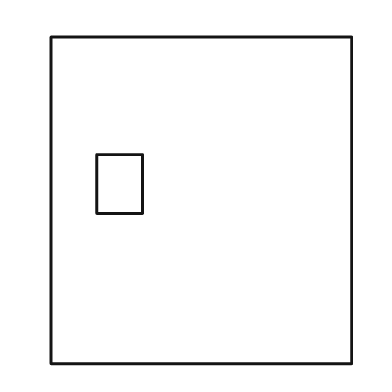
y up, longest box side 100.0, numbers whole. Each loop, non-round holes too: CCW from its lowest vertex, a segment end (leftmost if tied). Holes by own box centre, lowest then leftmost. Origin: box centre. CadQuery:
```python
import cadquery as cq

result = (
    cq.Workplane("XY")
    .moveTo(-46.0, -50.0)
    .lineTo(46.0, -50.0)
    .lineTo(46.0, 50.0)
    .lineTo(-46.0, 50.0)
    .close()
    .moveTo(-32.0, -4.0)
    .lineTo(-18.0, -4.0)
    .lineTo(-18.0, 14.0)
    .lineTo(-32.0, 14.0)
    .close()
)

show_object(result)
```